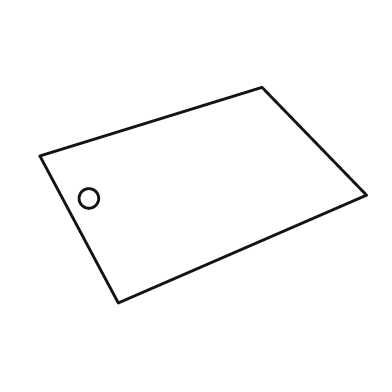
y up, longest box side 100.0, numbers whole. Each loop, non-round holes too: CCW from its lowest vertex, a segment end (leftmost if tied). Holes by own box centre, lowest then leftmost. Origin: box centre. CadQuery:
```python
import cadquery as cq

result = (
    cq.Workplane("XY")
    .moveTo(-26.0, -33.0)
    .lineTo(50.0, 0.0)
    .lineTo(18.0, 33.0)
    .lineTo(-50.0, 12.0)
    .close()
    .moveTo(-35.0, -1.0)
    .circle(3.0)
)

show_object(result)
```